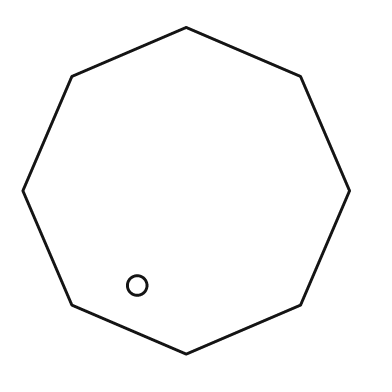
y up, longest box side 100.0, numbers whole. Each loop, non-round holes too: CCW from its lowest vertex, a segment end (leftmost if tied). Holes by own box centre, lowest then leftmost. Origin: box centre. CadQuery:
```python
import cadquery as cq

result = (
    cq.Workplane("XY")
    .moveTo(0.0, -50.0)
    .lineTo(35.0, -35.0)
    .lineTo(50.0, 0.0)
    .lineTo(35.0, 35.0)
    .lineTo(0.0, 50.0)
    .lineTo(-35.0, 35.0)
    .lineTo(-50.0, 0.0)
    .lineTo(-35.0, -35.0)
    .close()
    .moveTo(-15.0, -29.0)
    .circle(3.0)
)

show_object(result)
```